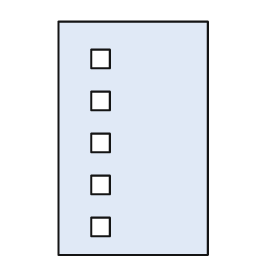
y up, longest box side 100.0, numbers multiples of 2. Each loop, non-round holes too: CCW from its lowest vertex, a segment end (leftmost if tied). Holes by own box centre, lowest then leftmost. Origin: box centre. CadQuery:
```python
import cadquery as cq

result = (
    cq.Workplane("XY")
    .moveTo(-32.0, -50.0)
    .lineTo(32.0, -50.0)
    .lineTo(32.0, 50.0)
    .lineTo(-32.0, 50.0)
    .close()
    .moveTo(-18.0, -42.0)
    .lineTo(-10.0, -42.0)
    .lineTo(-10.0, -34.0)
    .lineTo(-18.0, -34.0)
    .close()
    .moveTo(-18.0, -24.0)
    .lineTo(-10.0, -24.0)
    .lineTo(-10.0, -16.0)
    .lineTo(-18.0, -16.0)
    .close()
    .moveTo(-18.0, -6.0)
    .lineTo(-10.0, -6.0)
    .lineTo(-10.0, 2.0)
    .lineTo(-18.0, 2.0)
    .close()
    .moveTo(-18.0, 12.0)
    .lineTo(-10.0, 12.0)
    .lineTo(-10.0, 20.0)
    .lineTo(-18.0, 20.0)
    .close()
    .moveTo(-18.0, 30.0)
    .lineTo(-10.0, 30.0)
    .lineTo(-10.0, 38.0)
    .lineTo(-18.0, 38.0)
    .close()
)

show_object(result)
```